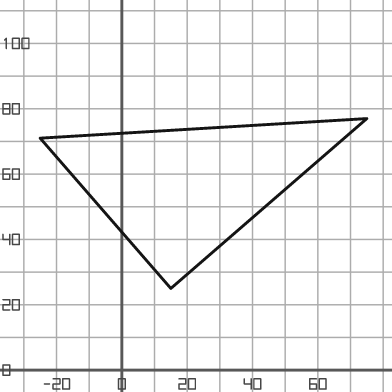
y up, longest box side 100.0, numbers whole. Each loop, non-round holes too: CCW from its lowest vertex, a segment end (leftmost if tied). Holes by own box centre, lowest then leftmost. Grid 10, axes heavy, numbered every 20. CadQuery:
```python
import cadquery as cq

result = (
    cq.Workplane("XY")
    .moveTo(15.0, 25.0)
    .lineTo(75.0, 77.0)
    .lineTo(-25.0, 71.0)
    .close()
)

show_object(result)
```